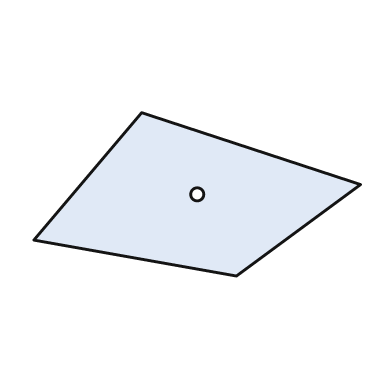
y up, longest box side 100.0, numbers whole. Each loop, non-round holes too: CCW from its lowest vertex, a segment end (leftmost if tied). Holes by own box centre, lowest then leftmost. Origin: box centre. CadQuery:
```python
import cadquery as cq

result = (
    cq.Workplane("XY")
    .moveTo(12.0, -25.0)
    .lineTo(50.0, 3.0)
    .lineTo(-17.0, 25.0)
    .lineTo(-50.0, -14.0)
    .close()
    .moveTo(0.0, 0.0)
    .circle(2.0)
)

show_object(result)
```